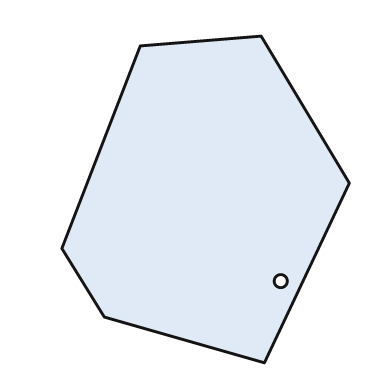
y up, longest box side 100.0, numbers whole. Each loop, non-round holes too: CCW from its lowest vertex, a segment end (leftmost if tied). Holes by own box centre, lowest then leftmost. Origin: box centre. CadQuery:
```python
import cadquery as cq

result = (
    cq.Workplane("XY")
    .moveTo(18.0, -50.0)
    .lineTo(44.0, 5.0)
    .lineTo(17.0, 50.0)
    .lineTo(-20.0, 47.0)
    .lineTo(-44.0, -15.0)
    .lineTo(-31.0, -36.0)
    .close()
    .moveTo(23.0, -25.0)
    .circle(2.0)
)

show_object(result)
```